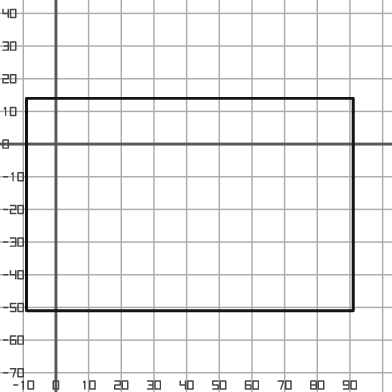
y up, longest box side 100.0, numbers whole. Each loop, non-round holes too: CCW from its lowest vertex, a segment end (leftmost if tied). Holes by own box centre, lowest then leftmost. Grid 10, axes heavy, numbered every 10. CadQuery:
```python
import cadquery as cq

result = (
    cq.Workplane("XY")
    .moveTo(-9.0, -51.0)
    .lineTo(91.0, -51.0)
    .lineTo(91.0, 14.0)
    .lineTo(-9.0, 14.0)
    .close()
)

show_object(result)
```